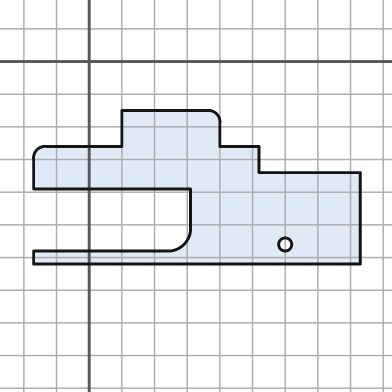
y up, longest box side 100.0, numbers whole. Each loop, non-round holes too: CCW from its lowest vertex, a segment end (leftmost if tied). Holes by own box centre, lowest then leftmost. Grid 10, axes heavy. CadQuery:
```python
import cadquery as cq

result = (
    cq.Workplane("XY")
    .moveTo(-17.0, -62.0)
    .lineTo(83.0, -62.0)
    .lineTo(83.0, -34.0)
    .lineTo(52.0, -34.0)
    .lineTo(52.0, -26.0)
    .lineTo(40.0, -26.0)
    .lineTo(40.0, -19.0)
    .threePointArc((39.0, -16.0), (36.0, -15.0))
    .lineTo(10.0, -15.0)
    .lineTo(10.0, -26.0)
    .lineTo(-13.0, -26.0)
    .threePointArc((-16.0, -27.0), (-17.0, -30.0))
    .lineTo(-17.0, -39.0)
    .lineTo(31.0, -39.0)
    .lineTo(31.0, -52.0)
    .threePointArc((29.0, -56.0), (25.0, -58.0))
    .lineTo(-17.0, -58.0)
    .close()
    .moveTo(60.0, -56.0)
    .circle(2.0)
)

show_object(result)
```